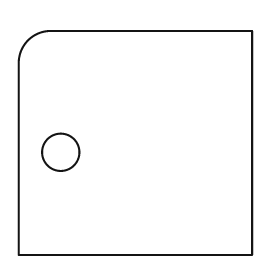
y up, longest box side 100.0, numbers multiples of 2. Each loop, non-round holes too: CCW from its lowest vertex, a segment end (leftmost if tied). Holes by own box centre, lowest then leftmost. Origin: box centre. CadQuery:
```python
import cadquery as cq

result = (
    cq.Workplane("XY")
    .moveTo(-50.0, -48.0)
    .lineTo(50.0, -48.0)
    .lineTo(50.0, 48.0)
    .lineTo(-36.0, 48.0)
    .threePointArc((-46.0, 44.0), (-50.0, 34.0))
    .close()
    .moveTo(-32.0, -4.0)
    .circle(8.0)
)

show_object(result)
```